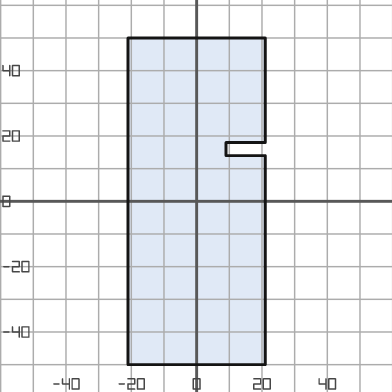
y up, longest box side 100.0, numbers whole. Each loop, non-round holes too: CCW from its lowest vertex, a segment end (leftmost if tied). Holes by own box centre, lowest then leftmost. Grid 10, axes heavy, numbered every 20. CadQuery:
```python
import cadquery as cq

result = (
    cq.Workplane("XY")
    .moveTo(-21.0, -50.0)
    .lineTo(21.0, -50.0)
    .lineTo(21.0, 14.0)
    .lineTo(9.0, 14.0)
    .lineTo(9.0, 18.0)
    .lineTo(21.0, 18.0)
    .lineTo(21.0, 50.0)
    .lineTo(-21.0, 50.0)
    .close()
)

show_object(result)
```